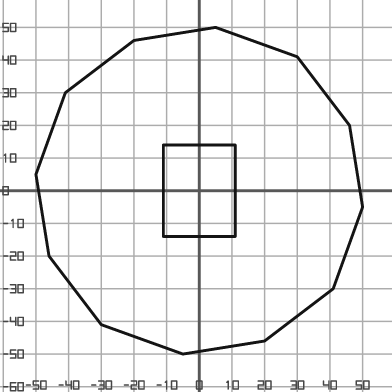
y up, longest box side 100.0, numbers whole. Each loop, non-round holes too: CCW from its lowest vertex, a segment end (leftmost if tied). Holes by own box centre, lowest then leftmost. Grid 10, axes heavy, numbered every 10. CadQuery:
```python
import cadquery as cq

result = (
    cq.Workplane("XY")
    .moveTo(-5.0, -50.0)
    .lineTo(20.0, -46.0)
    .lineTo(41.0, -30.0)
    .lineTo(50.0, -5.0)
    .lineTo(46.0, 20.0)
    .lineTo(30.0, 41.0)
    .lineTo(5.0, 50.0)
    .lineTo(-20.0, 46.0)
    .lineTo(-41.0, 30.0)
    .lineTo(-50.0, 5.0)
    .lineTo(-46.0, -20.0)
    .lineTo(-30.0, -41.0)
    .close()
    .moveTo(-11.0, -14.0)
    .lineTo(11.0, -14.0)
    .lineTo(11.0, 14.0)
    .lineTo(-11.0, 14.0)
    .close()
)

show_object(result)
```